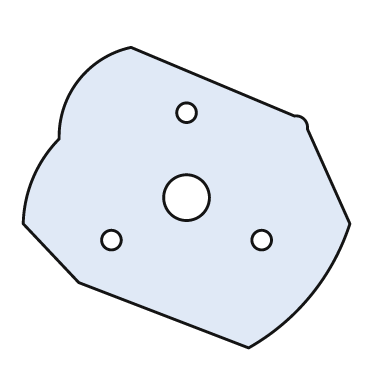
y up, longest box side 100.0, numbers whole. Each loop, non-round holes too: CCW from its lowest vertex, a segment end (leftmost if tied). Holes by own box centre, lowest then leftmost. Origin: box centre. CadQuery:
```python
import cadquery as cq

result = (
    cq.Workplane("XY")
    .moveTo(19.0, -46.0)
    .threePointArc((38.0, -30.0), (50.0, -8.0))
    .lineTo(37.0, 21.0)
    .threePointArc((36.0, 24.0), (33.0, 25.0))
    .lineTo(-17.0, 46.0)
    .threePointArc((-33.0, 36.0), (-39.0, 18.0))
    .threePointArc((-47.0, 6.0), (-50.0, -8.0))
    .lineTo(-33.0, -26.0)
    .close()
    .moveTo(-23.0, -13.0)
    .circle(3.0)
    .moveTo(23.0, -13.0)
    .circle(3.0)
    .moveTo(0.0, 0.0)
    .circle(7.0)
    .moveTo(0.0, 26.0)
    .circle(3.0)
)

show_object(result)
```